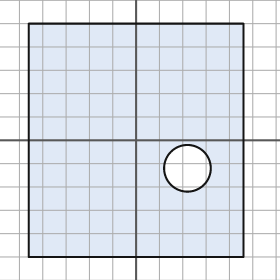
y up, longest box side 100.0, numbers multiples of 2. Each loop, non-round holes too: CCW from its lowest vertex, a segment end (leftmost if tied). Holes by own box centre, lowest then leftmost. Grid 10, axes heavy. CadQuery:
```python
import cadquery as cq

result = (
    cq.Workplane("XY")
    .moveTo(-46.0, -50.0)
    .lineTo(46.0, -50.0)
    .lineTo(46.0, 50.0)
    .lineTo(-46.0, 50.0)
    .close()
    .moveTo(22.0, -12.0)
    .circle(10.0)
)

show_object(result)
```